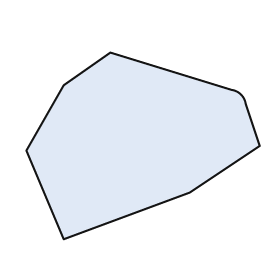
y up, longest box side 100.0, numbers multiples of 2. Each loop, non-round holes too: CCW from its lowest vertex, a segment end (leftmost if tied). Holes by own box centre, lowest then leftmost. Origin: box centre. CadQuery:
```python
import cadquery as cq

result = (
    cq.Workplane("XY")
    .moveTo(-34.0, -40.0)
    .lineTo(20.0, -20.0)
    .lineTo(50.0, 0.0)
    .lineTo(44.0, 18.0)
    .threePointArc((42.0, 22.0), (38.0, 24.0))
    .lineTo(-14.0, 40.0)
    .lineTo(-34.0, 26.0)
    .lineTo(-50.0, -2.0)
    .close()
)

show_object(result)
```